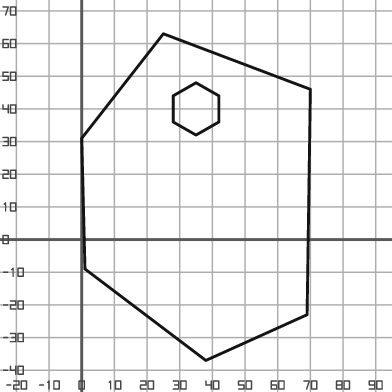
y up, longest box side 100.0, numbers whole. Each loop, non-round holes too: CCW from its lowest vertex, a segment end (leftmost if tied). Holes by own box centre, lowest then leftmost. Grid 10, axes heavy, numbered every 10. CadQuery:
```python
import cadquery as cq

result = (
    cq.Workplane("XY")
    .moveTo(38.0, -37.0)
    .lineTo(69.0, -23.0)
    .lineTo(70.0, 46.0)
    .lineTo(25.0, 63.0)
    .lineTo(0.0, 31.0)
    .lineTo(1.0, -9.0)
    .close()
    .moveTo(35.0, 32.0)
    .lineTo(42.0, 36.0)
    .lineTo(42.0, 44.0)
    .lineTo(35.0, 48.0)
    .lineTo(28.0, 44.0)
    .lineTo(28.0, 36.0)
    .close()
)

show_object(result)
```